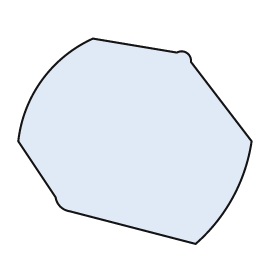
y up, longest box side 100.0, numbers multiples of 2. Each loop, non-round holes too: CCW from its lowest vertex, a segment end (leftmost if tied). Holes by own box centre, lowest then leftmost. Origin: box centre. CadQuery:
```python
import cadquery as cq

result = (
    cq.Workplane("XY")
    .moveTo(26.0, -44.0)
    .threePointArc((42.0, -24.0), (50.0, 0.0))
    .lineTo(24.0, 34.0)
    .threePointArc((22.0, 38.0), (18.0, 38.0))
    .lineTo(-18.0, 44.0)
    .threePointArc((-40.0, 26.0), (-50.0, 0.0))
    .lineTo(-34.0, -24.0)
    .threePointArc((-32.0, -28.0), (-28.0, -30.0))
    .close()
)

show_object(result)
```